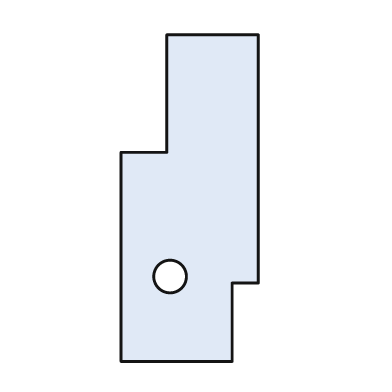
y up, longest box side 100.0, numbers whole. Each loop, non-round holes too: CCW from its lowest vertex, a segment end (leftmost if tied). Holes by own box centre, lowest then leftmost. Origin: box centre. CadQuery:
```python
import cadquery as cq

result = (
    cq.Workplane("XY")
    .moveTo(-21.0, -50.0)
    .lineTo(13.0, -50.0)
    .lineTo(13.0, -26.0)
    .lineTo(21.0, -26.0)
    .lineTo(21.0, 50.0)
    .lineTo(-7.0, 50.0)
    .lineTo(-7.0, 14.0)
    .lineTo(-21.0, 14.0)
    .close()
    .moveTo(-6.0, -24.0)
    .circle(5.0)
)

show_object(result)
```